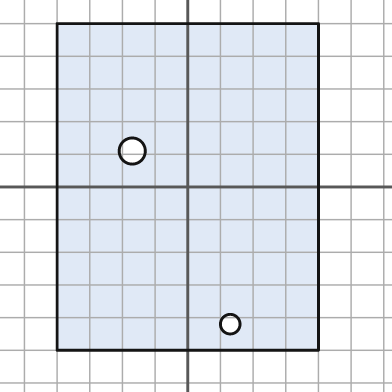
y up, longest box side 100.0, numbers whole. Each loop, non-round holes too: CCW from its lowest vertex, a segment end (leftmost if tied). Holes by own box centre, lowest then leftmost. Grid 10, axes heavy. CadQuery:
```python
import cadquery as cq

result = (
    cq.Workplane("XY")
    .moveTo(-40.0, -50.0)
    .lineTo(40.0, -50.0)
    .lineTo(40.0, 50.0)
    .lineTo(-40.0, 50.0)
    .close()
    .moveTo(13.0, -42.0)
    .circle(3.0)
    .moveTo(-17.0, 11.0)
    .circle(4.0)
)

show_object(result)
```